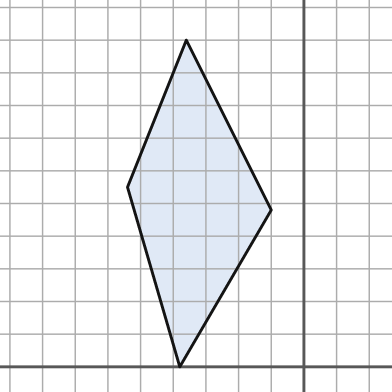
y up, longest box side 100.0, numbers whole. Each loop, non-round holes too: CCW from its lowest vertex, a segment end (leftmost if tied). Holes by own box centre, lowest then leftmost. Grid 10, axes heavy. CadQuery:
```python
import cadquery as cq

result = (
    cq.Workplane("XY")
    .moveTo(-38.0, 0.0)
    .lineTo(-10.0, 48.0)
    .lineTo(-36.0, 100.0)
    .lineTo(-54.0, 55.0)
    .close()
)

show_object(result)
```